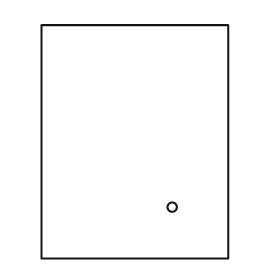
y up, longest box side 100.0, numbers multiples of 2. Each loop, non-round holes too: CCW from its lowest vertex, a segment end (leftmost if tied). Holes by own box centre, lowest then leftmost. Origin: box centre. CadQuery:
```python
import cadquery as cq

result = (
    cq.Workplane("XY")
    .moveTo(-40.0, -50.0)
    .lineTo(40.0, -50.0)
    .lineTo(40.0, 50.0)
    .lineTo(-40.0, 50.0)
    .close()
    .moveTo(16.0, -28.0)
    .circle(2.0)
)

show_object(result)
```